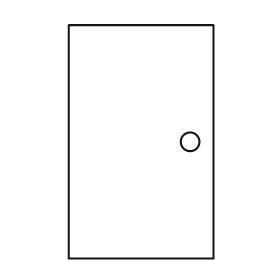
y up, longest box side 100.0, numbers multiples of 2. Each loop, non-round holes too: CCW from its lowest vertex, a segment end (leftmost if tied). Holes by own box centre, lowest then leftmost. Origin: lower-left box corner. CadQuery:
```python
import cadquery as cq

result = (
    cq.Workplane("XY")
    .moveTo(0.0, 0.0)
    .lineTo(62.0, 0.0)
    .lineTo(62.0, 100.0)
    .lineTo(0.0, 100.0)
    .close()
    .moveTo(52.0, 50.0)
    .circle(4.0)
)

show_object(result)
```